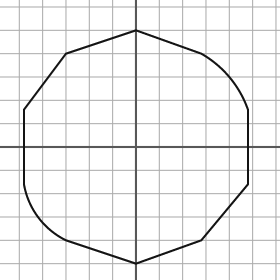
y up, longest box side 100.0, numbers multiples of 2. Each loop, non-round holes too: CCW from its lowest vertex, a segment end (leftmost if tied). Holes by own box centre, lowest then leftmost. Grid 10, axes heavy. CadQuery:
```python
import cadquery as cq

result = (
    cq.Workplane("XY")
    .moveTo(0.0, -50.0)
    .lineTo(28.0, -40.0)
    .lineTo(48.0, -16.0)
    .lineTo(48.0, 16.0)
    .threePointArc((40.0, 30.0), (28.0, 40.0))
    .lineTo(0.0, 50.0)
    .lineTo(-30.0, 40.0)
    .lineTo(-48.0, 16.0)
    .lineTo(-48.0, -16.0)
    .threePointArc((-42.0, -30.0), (-30.0, -40.0))
    .close()
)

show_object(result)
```